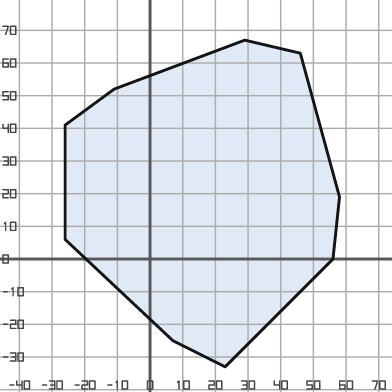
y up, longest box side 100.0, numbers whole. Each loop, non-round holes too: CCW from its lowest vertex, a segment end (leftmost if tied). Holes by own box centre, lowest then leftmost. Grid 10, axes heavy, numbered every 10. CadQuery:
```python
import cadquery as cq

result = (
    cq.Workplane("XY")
    .moveTo(23.0, -33.0)
    .lineTo(56.0, 0.0)
    .lineTo(58.0, 19.0)
    .lineTo(46.0, 63.0)
    .lineTo(29.0, 67.0)
    .lineTo(-11.0, 52.0)
    .lineTo(-26.0, 41.0)
    .lineTo(-26.0, 6.0)
    .lineTo(7.0, -25.0)
    .close()
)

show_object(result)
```